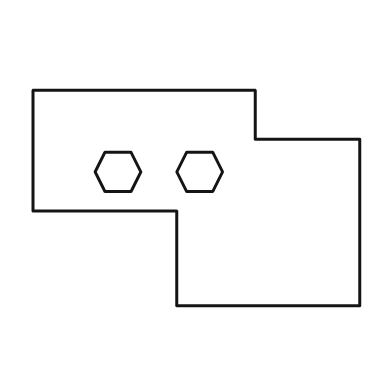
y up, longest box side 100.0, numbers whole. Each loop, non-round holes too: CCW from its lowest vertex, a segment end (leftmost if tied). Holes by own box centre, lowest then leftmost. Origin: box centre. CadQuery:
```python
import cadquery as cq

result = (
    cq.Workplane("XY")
    .moveTo(-6.0, -33.0)
    .lineTo(50.0, -33.0)
    .lineTo(50.0, 18.0)
    .lineTo(18.0, 18.0)
    .lineTo(18.0, 33.0)
    .lineTo(-50.0, 33.0)
    .lineTo(-50.0, -4.0)
    .lineTo(-6.0, -4.0)
    .close()
    .moveTo(-28.0, 2.0)
    .lineTo(-20.0, 2.0)
    .lineTo(-17.0, 8.0)
    .lineTo(-20.0, 14.0)
    .lineTo(-28.0, 14.0)
    .lineTo(-31.0, 8.0)
    .close()
    .moveTo(-3.0, 2.0)
    .lineTo(5.0, 2.0)
    .lineTo(8.0, 8.0)
    .lineTo(5.0, 14.0)
    .lineTo(-3.0, 14.0)
    .lineTo(-6.0, 8.0)
    .close()
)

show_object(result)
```